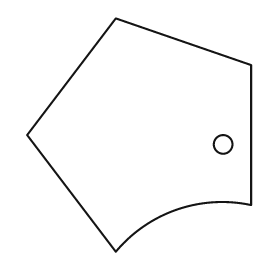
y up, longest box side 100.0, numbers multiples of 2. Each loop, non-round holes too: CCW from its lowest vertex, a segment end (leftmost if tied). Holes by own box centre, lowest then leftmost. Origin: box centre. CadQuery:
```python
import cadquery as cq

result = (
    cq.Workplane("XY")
    .moveTo(-10.0, -50.0)
    .threePointArc((16.0, -32.0), (48.0, -30.0))
    .lineTo(48.0, 30.0)
    .lineTo(-10.0, 50.0)
    .lineTo(-48.0, 0.0)
    .close()
    .moveTo(36.0, -4.0)
    .circle(4.0)
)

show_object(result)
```